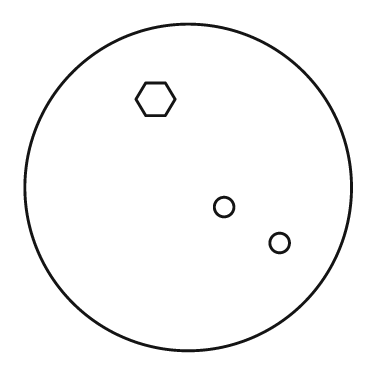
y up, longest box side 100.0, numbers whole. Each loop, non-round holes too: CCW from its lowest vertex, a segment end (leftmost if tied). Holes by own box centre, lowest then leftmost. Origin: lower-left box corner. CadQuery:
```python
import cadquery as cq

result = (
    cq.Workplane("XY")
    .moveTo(50.0, 50.0)
    .circle(50.0)
    .moveTo(78.0, 33.0)
    .circle(3.0)
    .moveTo(61.0, 44.0)
    .circle(3.0)
    .moveTo(37.0, 72.0)
    .lineTo(43.0, 72.0)
    .lineTo(46.0, 77.0)
    .lineTo(43.0, 82.0)
    .lineTo(37.0, 82.0)
    .lineTo(34.0, 77.0)
    .close()
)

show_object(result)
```